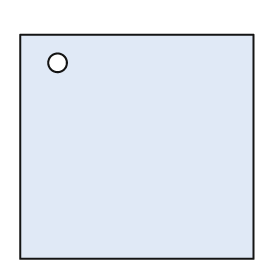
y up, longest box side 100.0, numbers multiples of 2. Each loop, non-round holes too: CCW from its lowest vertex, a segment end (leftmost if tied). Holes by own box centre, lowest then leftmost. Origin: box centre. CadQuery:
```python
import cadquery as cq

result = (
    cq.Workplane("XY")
    .moveTo(-50.0, -48.0)
    .lineTo(50.0, -48.0)
    .lineTo(50.0, 48.0)
    .lineTo(-50.0, 48.0)
    .close()
    .moveTo(-34.0, 36.0)
    .circle(4.0)
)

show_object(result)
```